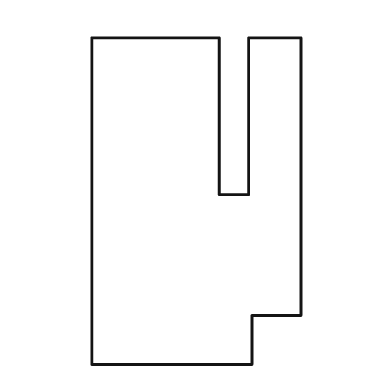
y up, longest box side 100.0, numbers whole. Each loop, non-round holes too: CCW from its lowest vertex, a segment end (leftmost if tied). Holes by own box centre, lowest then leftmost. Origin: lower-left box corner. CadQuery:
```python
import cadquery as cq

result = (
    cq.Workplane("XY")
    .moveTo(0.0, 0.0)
    .lineTo(49.0, 0.0)
    .lineTo(49.0, 15.0)
    .lineTo(64.0, 15.0)
    .lineTo(64.0, 100.0)
    .lineTo(48.0, 100.0)
    .lineTo(48.0, 52.0)
    .lineTo(39.0, 52.0)
    .lineTo(39.0, 100.0)
    .lineTo(0.0, 100.0)
    .close()
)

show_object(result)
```